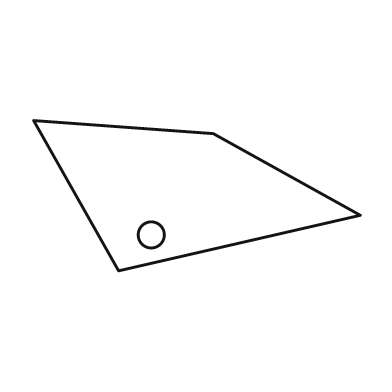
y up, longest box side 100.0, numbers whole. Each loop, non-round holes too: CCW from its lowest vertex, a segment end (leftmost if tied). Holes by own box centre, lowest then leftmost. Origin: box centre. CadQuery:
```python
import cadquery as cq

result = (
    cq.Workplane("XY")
    .moveTo(-24.0, -23.0)
    .lineTo(50.0, -6.0)
    .lineTo(5.0, 19.0)
    .lineTo(-50.0, 23.0)
    .close()
    .moveTo(-14.0, -12.0)
    .circle(4.0)
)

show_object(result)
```